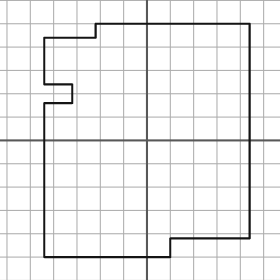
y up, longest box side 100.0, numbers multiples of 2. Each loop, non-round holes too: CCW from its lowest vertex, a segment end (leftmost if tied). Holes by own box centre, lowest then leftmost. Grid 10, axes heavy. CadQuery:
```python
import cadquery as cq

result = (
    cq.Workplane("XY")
    .moveTo(-44.0, -50.0)
    .lineTo(10.0, -50.0)
    .lineTo(10.0, -42.0)
    .lineTo(44.0, -42.0)
    .lineTo(44.0, 50.0)
    .lineTo(-22.0, 50.0)
    .lineTo(-22.0, 44.0)
    .lineTo(-44.0, 44.0)
    .lineTo(-44.0, 24.0)
    .lineTo(-32.0, 24.0)
    .lineTo(-32.0, 16.0)
    .lineTo(-44.0, 16.0)
    .close()
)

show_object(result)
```